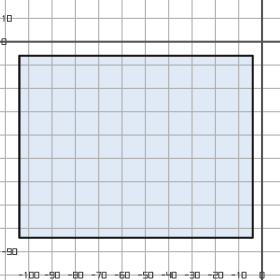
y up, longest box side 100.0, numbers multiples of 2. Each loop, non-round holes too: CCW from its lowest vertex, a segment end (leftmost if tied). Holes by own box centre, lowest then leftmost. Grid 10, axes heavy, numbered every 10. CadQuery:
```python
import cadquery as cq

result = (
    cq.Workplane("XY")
    .moveTo(-104.0, -84.0)
    .lineTo(-4.0, -84.0)
    .lineTo(-4.0, -6.0)
    .lineTo(-104.0, -6.0)
    .close()
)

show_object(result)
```